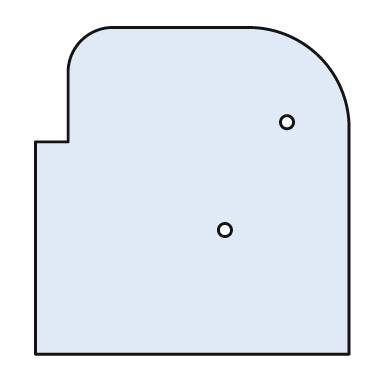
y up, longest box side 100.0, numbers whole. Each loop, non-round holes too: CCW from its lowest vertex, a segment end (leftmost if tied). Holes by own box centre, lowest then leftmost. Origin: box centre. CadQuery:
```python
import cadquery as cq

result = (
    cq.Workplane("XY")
    .moveTo(-48.0, -50.0)
    .lineTo(48.0, -50.0)
    .lineTo(48.0, 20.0)
    .threePointArc((39.0, 41.0), (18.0, 50.0))
    .lineTo(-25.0, 50.0)
    .threePointArc((-34.0, 46.0), (-38.0, 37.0))
    .lineTo(-38.0, 15.0)
    .lineTo(-48.0, 15.0)
    .close()
    .moveTo(10.0, -12.0)
    .circle(2.0)
    .moveTo(29.0, 21.0)
    .circle(2.0)
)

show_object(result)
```